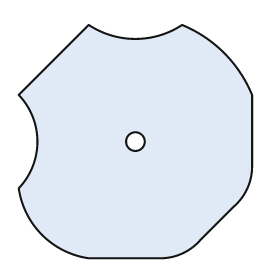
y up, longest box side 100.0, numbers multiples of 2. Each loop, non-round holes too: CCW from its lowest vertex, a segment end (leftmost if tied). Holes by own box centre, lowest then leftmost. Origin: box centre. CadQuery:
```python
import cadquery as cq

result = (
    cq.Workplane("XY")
    .moveTo(-20.0, -50.0)
    .lineTo(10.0, -50.0)
    .threePointArc((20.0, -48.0), (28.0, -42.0))
    .lineTo(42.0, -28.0)
    .threePointArc((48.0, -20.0), (50.0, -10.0))
    .lineTo(50.0, 20.0)
    .threePointArc((38.0, 38.0), (20.0, 50.0))
    .threePointArc((0.0, 44.0), (-20.0, 50.0))
    .lineTo(-50.0, 20.0)
    .threePointArc((-42.0, 0.0), (-50.0, -20.0))
    .threePointArc((-40.0, -40.0), (-20.0, -50.0))
    .close()
    .moveTo(0.0, 0.0)
    .circle(4.0)
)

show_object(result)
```